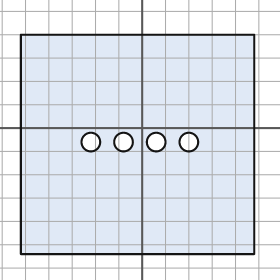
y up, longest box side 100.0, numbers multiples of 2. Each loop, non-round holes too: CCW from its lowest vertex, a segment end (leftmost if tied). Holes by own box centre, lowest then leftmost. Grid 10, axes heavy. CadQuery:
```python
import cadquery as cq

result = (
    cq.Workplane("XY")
    .moveTo(-52.0, -54.0)
    .lineTo(48.0, -54.0)
    .lineTo(48.0, 40.0)
    .lineTo(-52.0, 40.0)
    .close()
    .moveTo(-22.0, -6.0)
    .circle(4.0)
    .moveTo(-8.0, -6.0)
    .circle(4.0)
    .moveTo(6.0, -6.0)
    .circle(4.0)
    .moveTo(20.0, -6.0)
    .circle(4.0)
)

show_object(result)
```